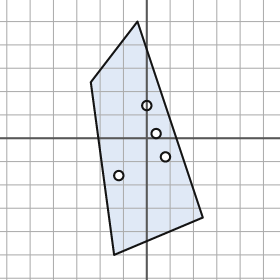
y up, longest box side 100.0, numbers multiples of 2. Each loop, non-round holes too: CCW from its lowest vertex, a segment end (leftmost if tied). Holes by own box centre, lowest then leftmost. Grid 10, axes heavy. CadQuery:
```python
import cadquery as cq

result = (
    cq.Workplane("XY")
    .moveTo(-14.0, -50.0)
    .lineTo(24.0, -34.0)
    .lineTo(-4.0, 50.0)
    .lineTo(-24.0, 24.0)
    .close()
    .moveTo(-12.0, -16.0)
    .circle(2.0)
    .moveTo(8.0, -8.0)
    .circle(2.0)
    .moveTo(4.0, 2.0)
    .circle(2.0)
    .moveTo(0.0, 14.0)
    .circle(2.0)
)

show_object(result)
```